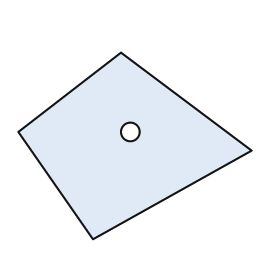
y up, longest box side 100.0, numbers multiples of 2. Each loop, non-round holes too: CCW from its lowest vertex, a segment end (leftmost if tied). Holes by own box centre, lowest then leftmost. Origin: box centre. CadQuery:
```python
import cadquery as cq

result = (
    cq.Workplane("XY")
    .moveTo(-18.0, -40.0)
    .lineTo(50.0, -2.0)
    .lineTo(-6.0, 40.0)
    .lineTo(-50.0, 6.0)
    .close()
    .moveTo(-2.0, 6.0)
    .circle(4.0)
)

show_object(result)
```